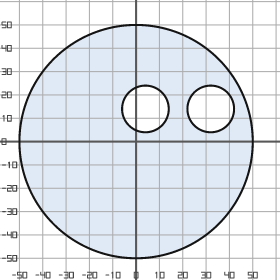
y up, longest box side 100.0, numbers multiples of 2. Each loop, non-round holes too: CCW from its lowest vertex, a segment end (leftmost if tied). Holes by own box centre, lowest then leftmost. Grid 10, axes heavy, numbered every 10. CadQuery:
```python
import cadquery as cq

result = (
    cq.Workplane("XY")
    .moveTo(0.0, 0.0)
    .circle(50.0)
    .moveTo(4.0, 14.0)
    .circle(10.0)
    .moveTo(32.0, 14.0)
    .circle(10.0)
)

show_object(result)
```